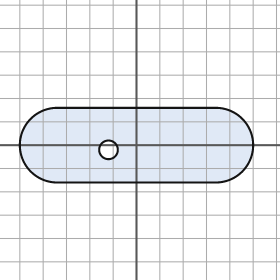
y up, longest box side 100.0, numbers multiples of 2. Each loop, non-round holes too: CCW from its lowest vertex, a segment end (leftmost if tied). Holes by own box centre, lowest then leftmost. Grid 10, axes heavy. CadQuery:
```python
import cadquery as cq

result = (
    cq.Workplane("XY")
    .moveTo(-34.0, -16.0)
    .lineTo(34.0, -16.0)
    .threePointArc((50.0, 0.0), (34.0, 16.0))
    .lineTo(-34.0, 16.0)
    .threePointArc((-50.0, 0.0), (-34.0, -16.0))
    .close()
    .moveTo(-12.0, -2.0)
    .circle(4.0)
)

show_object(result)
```